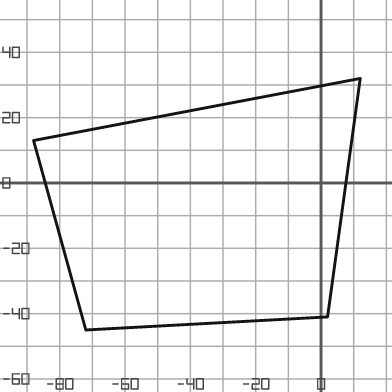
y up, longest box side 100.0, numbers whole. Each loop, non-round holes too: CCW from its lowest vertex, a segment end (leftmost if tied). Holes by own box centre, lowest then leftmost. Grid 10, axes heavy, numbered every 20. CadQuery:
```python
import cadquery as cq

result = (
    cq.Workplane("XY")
    .moveTo(-72.0, -45.0)
    .lineTo(2.0, -41.0)
    .lineTo(12.0, 32.0)
    .lineTo(-88.0, 13.0)
    .close()
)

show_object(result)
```